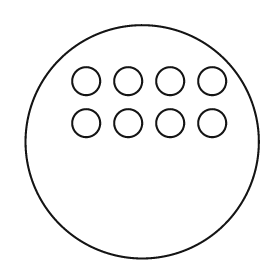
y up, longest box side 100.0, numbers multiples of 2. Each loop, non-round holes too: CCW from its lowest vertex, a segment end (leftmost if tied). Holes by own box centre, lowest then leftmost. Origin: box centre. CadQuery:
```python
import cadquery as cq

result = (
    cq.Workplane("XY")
    .moveTo(0.0, 0.0)
    .circle(50.0)
    .moveTo(-24.0, 8.0)
    .circle(6.0)
    .moveTo(-6.0, 8.0)
    .circle(6.0)
    .moveTo(12.0, 8.0)
    .circle(6.0)
    .moveTo(30.0, 8.0)
    .circle(6.0)
    .moveTo(-24.0, 26.0)
    .circle(6.0)
    .moveTo(-6.0, 26.0)
    .circle(6.0)
    .moveTo(12.0, 26.0)
    .circle(6.0)
    .moveTo(30.0, 26.0)
    .circle(6.0)
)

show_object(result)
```